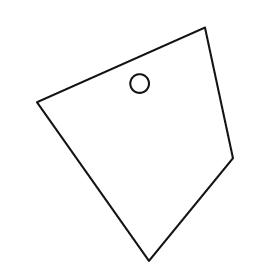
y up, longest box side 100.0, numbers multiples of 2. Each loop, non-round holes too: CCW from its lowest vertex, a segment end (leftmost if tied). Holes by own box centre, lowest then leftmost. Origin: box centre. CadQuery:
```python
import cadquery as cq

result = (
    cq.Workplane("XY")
    .moveTo(6.0, -50.0)
    .lineTo(42.0, -6.0)
    .lineTo(30.0, 50.0)
    .lineTo(-42.0, 18.0)
    .close()
    .moveTo(2.0, 26.0)
    .circle(4.0)
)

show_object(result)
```